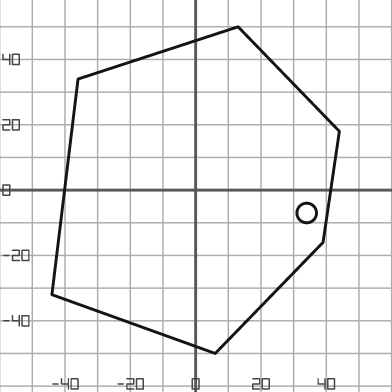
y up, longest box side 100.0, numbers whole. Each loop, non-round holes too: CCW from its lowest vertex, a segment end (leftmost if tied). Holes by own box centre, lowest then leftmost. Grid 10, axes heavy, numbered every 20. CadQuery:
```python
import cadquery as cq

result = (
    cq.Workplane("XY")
    .moveTo(6.0, -50.0)
    .lineTo(39.0, -16.0)
    .lineTo(44.0, 18.0)
    .lineTo(13.0, 50.0)
    .lineTo(-36.0, 34.0)
    .lineTo(-44.0, -32.0)
    .close()
    .moveTo(34.0, -7.0)
    .circle(3.0)
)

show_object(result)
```